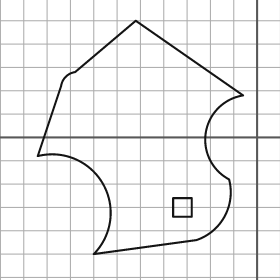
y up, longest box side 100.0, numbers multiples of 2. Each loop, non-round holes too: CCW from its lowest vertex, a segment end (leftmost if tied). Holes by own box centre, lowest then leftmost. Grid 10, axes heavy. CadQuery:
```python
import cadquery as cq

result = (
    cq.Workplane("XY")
    .moveTo(-70.0, -50.0)
    .lineTo(-26.0, -44.0)
    .threePointArc((-14.0, -34.0), (-12.0, -18.0))
    .threePointArc((-22.0, 2.0), (-6.0, 18.0))
    .lineTo(-52.0, 50.0)
    .lineTo(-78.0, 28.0)
    .threePointArc((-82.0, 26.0), (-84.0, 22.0))
    .lineTo(-94.0, -8.0)
    .threePointArc((-66.0, -20.0), (-70.0, -50.0))
    .close()
    .moveTo(-36.0, -34.0)
    .lineTo(-28.0, -34.0)
    .lineTo(-28.0, -26.0)
    .lineTo(-36.0, -26.0)
    .close()
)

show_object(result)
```